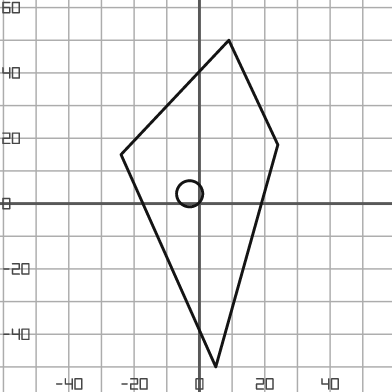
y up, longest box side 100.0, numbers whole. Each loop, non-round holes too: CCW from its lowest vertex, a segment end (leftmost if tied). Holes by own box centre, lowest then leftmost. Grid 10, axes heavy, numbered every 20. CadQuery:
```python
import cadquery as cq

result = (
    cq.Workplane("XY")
    .moveTo(5.0, -50.0)
    .lineTo(24.0, 18.0)
    .lineTo(9.0, 50.0)
    .lineTo(-24.0, 15.0)
    .close()
    .moveTo(-3.0, 3.0)
    .circle(4.0)
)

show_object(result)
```